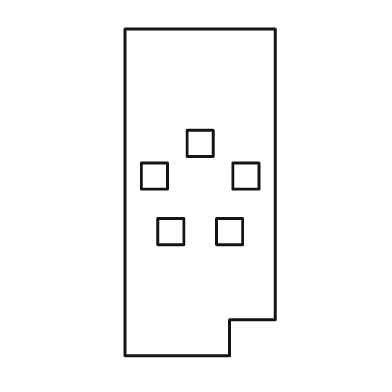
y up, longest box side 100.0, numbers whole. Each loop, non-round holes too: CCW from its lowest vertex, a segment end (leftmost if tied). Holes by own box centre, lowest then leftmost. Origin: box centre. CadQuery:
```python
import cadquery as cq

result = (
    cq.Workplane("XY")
    .moveTo(-23.0, -50.0)
    .lineTo(9.0, -50.0)
    .lineTo(9.0, -39.0)
    .lineTo(23.0, -39.0)
    .lineTo(23.0, 50.0)
    .lineTo(-23.0, 50.0)
    .close()
    .moveTo(-13.0, -16.0)
    .lineTo(-5.0, -16.0)
    .lineTo(-5.0, -8.0)
    .lineTo(-13.0, -8.0)
    .close()
    .moveTo(5.0, -16.0)
    .lineTo(13.0, -16.0)
    .lineTo(13.0, -8.0)
    .lineTo(5.0, -8.0)
    .close()
    .moveTo(-18.0, 1.0)
    .lineTo(-10.0, 1.0)
    .lineTo(-10.0, 9.0)
    .lineTo(-18.0, 9.0)
    .close()
    .moveTo(10.0, 1.0)
    .lineTo(18.0, 1.0)
    .lineTo(18.0, 9.0)
    .lineTo(10.0, 9.0)
    .close()
    .moveTo(-4.0, 11.0)
    .lineTo(4.0, 11.0)
    .lineTo(4.0, 19.0)
    .lineTo(-4.0, 19.0)
    .close()
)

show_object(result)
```